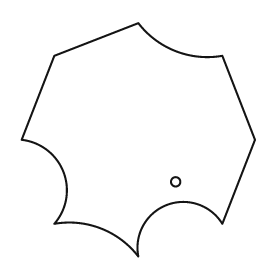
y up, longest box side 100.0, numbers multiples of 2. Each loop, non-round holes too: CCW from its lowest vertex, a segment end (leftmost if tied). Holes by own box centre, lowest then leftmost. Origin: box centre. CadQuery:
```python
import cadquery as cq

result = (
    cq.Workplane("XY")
    .moveTo(0.0, -50.0)
    .threePointArc((12.0, -28.0), (36.0, -36.0))
    .lineTo(50.0, 0.0)
    .lineTo(36.0, 36.0)
    .threePointArc((16.0, 38.0), (0.0, 50.0))
    .lineTo(-36.0, 36.0)
    .lineTo(-50.0, 0.0)
    .threePointArc((-32.0, -14.0), (-36.0, -36.0))
    .threePointArc((-16.0, -38.0), (0.0, -50.0))
    .close()
    .moveTo(16.0, -18.0)
    .circle(2.0)
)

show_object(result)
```